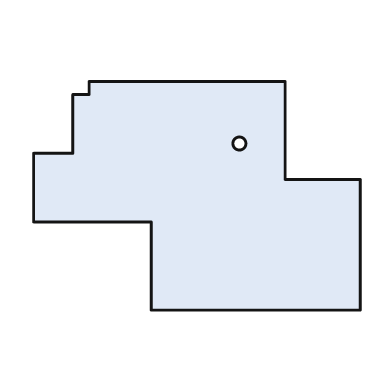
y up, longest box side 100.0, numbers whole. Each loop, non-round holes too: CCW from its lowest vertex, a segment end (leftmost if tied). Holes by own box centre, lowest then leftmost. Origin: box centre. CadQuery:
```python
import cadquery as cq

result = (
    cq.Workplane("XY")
    .moveTo(-14.0, -35.0)
    .lineTo(50.0, -35.0)
    .lineTo(50.0, 5.0)
    .lineTo(27.0, 5.0)
    .lineTo(27.0, 35.0)
    .lineTo(-33.0, 35.0)
    .lineTo(-33.0, 31.0)
    .lineTo(-38.0, 31.0)
    .lineTo(-38.0, 13.0)
    .lineTo(-50.0, 13.0)
    .lineTo(-50.0, -8.0)
    .lineTo(-14.0, -8.0)
    .close()
    .moveTo(13.0, 16.0)
    .circle(2.0)
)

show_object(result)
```